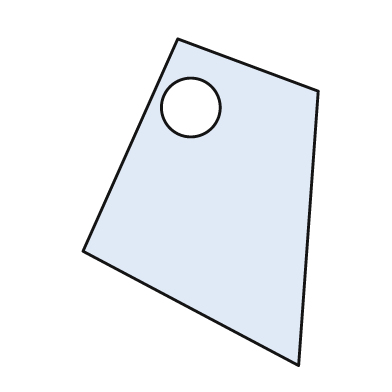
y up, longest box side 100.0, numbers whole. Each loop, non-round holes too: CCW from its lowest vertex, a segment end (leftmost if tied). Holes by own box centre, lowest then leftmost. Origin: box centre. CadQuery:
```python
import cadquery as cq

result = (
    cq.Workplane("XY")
    .moveTo(30.0, -50.0)
    .lineTo(36.0, 34.0)
    .lineTo(-7.0, 50.0)
    .lineTo(-36.0, -15.0)
    .close()
    .moveTo(-3.0, 29.0)
    .circle(9.0)
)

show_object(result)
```